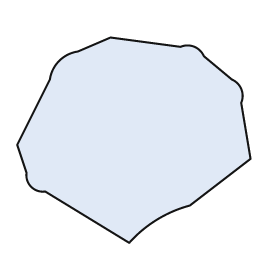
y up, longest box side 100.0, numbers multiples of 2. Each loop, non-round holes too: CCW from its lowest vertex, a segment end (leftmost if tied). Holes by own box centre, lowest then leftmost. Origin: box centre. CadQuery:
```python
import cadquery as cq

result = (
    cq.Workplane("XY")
    .moveTo(-2.0, -44.0)
    .threePointArc((10.0, -34.0), (24.0, -28.0))
    .lineTo(50.0, -8.0)
    .lineTo(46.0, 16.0)
    .threePointArc((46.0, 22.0), (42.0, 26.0))
    .lineTo(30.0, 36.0)
    .threePointArc((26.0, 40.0), (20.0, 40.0))
    .lineTo(-10.0, 44.0)
    .lineTo(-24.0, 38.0)
    .threePointArc((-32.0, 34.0), (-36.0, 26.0))
    .lineTo(-50.0, -2.0)
    .lineTo(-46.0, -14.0)
    .threePointArc((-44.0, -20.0), (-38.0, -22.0))
    .close()
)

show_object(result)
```